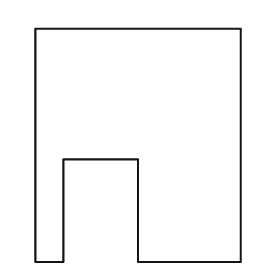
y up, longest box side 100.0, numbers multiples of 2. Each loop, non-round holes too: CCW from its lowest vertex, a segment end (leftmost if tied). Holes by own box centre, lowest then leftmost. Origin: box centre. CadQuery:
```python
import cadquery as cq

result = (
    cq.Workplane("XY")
    .moveTo(-44.0, -50.0)
    .lineTo(-32.0, -50.0)
    .lineTo(-32.0, -6.0)
    .lineTo(0.0, -6.0)
    .lineTo(0.0, -50.0)
    .lineTo(44.0, -50.0)
    .lineTo(44.0, 50.0)
    .lineTo(-44.0, 50.0)
    .close()
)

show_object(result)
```